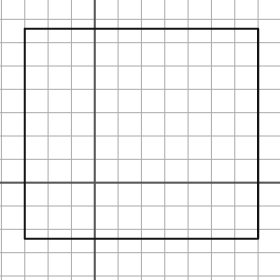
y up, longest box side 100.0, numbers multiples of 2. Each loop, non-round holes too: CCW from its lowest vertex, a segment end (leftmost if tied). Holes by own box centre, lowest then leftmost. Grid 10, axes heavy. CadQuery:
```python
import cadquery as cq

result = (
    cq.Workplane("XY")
    .moveTo(-30.0, -24.0)
    .lineTo(70.0, -24.0)
    .lineTo(70.0, 66.0)
    .lineTo(-30.0, 66.0)
    .close()
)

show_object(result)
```